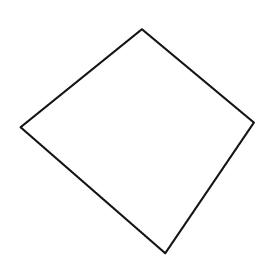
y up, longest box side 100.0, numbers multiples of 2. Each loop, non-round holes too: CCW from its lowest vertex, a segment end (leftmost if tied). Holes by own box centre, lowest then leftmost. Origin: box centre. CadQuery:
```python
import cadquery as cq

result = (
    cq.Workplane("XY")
    .moveTo(12.0, -48.0)
    .lineTo(50.0, 8.0)
    .lineTo(2.0, 48.0)
    .lineTo(-50.0, 6.0)
    .close()
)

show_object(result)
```